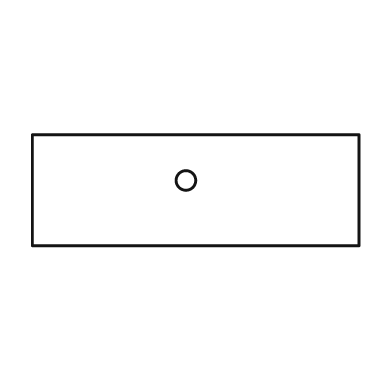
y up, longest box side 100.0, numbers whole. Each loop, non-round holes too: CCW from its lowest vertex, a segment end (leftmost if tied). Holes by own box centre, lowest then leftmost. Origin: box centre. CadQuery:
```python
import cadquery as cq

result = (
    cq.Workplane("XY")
    .moveTo(-50.0, -17.0)
    .lineTo(50.0, -17.0)
    .lineTo(50.0, 17.0)
    .lineTo(-50.0, 17.0)
    .close()
    .moveTo(-3.0, 3.0)
    .circle(3.0)
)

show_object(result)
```